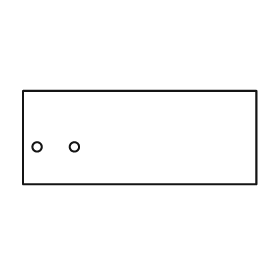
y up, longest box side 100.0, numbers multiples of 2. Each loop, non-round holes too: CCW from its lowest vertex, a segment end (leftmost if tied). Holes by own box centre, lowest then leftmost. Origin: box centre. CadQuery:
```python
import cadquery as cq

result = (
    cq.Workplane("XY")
    .moveTo(-50.0, -20.0)
    .lineTo(50.0, -20.0)
    .lineTo(50.0, 20.0)
    .lineTo(-50.0, 20.0)
    .close()
    .moveTo(-44.0, -4.0)
    .circle(2.0)
    .moveTo(-28.0, -4.0)
    .circle(2.0)
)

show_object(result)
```